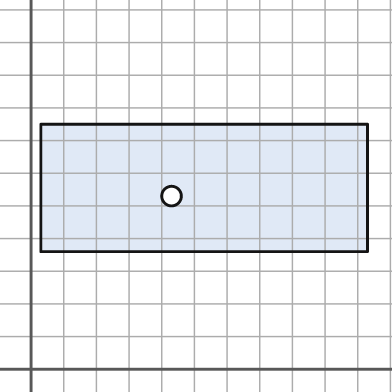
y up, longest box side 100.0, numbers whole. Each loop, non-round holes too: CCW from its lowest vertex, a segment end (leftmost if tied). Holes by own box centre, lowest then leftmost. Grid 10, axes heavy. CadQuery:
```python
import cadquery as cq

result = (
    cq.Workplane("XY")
    .moveTo(3.0, 36.0)
    .lineTo(103.0, 36.0)
    .lineTo(103.0, 75.0)
    .lineTo(3.0, 75.0)
    .close()
    .moveTo(43.0, 53.0)
    .circle(3.0)
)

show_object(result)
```